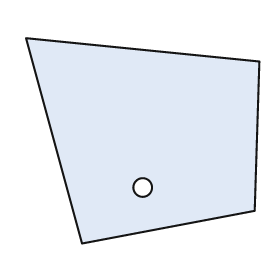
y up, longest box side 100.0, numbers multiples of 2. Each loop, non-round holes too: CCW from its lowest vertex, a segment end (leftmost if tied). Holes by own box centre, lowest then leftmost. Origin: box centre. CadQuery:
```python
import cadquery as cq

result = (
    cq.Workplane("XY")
    .moveTo(-26.0, -44.0)
    .lineTo(48.0, -30.0)
    .lineTo(50.0, 34.0)
    .lineTo(-50.0, 44.0)
    .close()
    .moveTo(0.0, -20.0)
    .circle(4.0)
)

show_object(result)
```